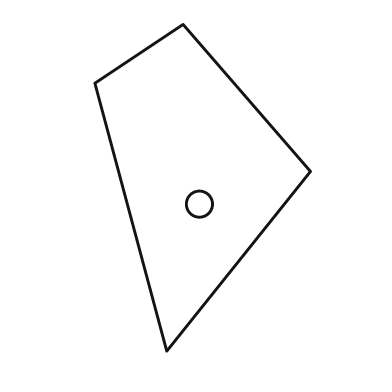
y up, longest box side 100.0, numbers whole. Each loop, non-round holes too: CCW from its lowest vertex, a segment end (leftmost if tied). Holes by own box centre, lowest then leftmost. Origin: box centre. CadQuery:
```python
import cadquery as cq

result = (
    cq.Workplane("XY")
    .moveTo(-11.0, -50.0)
    .lineTo(33.0, 5.0)
    .lineTo(-6.0, 50.0)
    .lineTo(-33.0, 32.0)
    .close()
    .moveTo(-1.0, -5.0)
    .circle(4.0)
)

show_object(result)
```